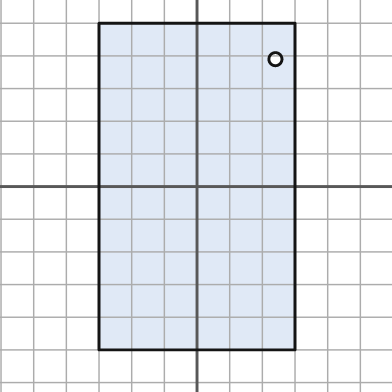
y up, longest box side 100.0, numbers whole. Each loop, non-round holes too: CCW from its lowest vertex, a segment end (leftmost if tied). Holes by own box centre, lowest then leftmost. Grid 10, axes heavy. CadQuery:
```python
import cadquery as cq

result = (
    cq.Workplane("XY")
    .moveTo(-30.0, -50.0)
    .lineTo(30.0, -50.0)
    .lineTo(30.0, 50.0)
    .lineTo(-30.0, 50.0)
    .close()
    .moveTo(24.0, 39.0)
    .circle(2.0)
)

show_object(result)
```